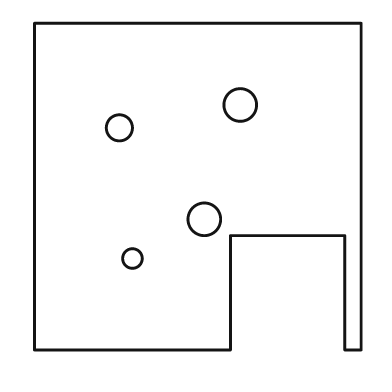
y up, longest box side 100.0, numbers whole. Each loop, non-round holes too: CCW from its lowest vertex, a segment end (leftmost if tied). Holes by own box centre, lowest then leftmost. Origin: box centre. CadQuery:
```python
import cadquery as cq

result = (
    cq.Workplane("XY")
    .moveTo(-50.0, -50.0)
    .lineTo(10.0, -50.0)
    .lineTo(10.0, -15.0)
    .lineTo(45.0, -15.0)
    .lineTo(45.0, -50.0)
    .lineTo(50.0, -50.0)
    .lineTo(50.0, 50.0)
    .lineTo(-50.0, 50.0)
    .close()
    .moveTo(-20.0, -22.0)
    .circle(3.0)
    .moveTo(2.0, -10.0)
    .circle(5.0)
    .moveTo(-24.0, 18.0)
    .circle(4.0)
    .moveTo(13.0, 25.0)
    .circle(5.0)
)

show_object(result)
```